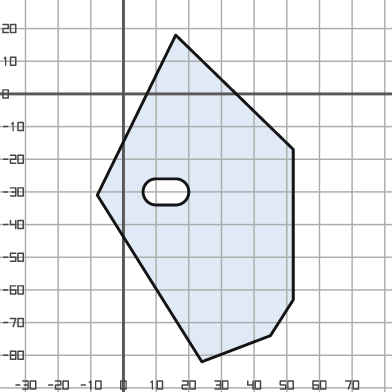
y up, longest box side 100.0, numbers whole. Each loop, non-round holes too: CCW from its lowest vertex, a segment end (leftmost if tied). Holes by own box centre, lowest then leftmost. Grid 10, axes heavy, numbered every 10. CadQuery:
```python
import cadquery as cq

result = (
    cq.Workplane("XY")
    .moveTo(24.0, -82.0)
    .lineTo(45.0, -74.0)
    .lineTo(52.0, -63.0)
    .lineTo(52.0, -17.0)
    .lineTo(16.0, 18.0)
    .lineTo(-8.0, -31.0)
    .close()
    .moveTo(10.0, -34.0)
    .lineTo(16.0, -34.0)
    .threePointArc((20.0, -30.0), (16.0, -26.0))
    .lineTo(10.0, -26.0)
    .threePointArc((6.0, -30.0), (10.0, -34.0))
    .close()
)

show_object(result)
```